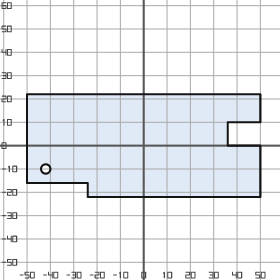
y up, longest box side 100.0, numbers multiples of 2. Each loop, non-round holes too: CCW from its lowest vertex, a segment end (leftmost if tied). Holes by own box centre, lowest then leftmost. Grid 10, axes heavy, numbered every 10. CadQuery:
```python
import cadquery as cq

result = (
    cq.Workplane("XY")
    .moveTo(-24.0, -22.0)
    .lineTo(50.0, -22.0)
    .lineTo(50.0, 0.0)
    .lineTo(36.0, 0.0)
    .lineTo(36.0, 10.0)
    .lineTo(50.0, 10.0)
    .lineTo(50.0, 22.0)
    .lineTo(-50.0, 22.0)
    .lineTo(-50.0, -16.0)
    .lineTo(-24.0, -16.0)
    .close()
    .moveTo(-42.0, -10.0)
    .circle(2.0)
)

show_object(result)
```